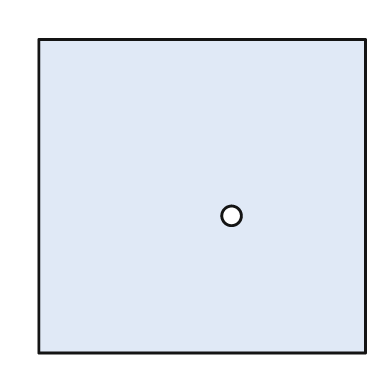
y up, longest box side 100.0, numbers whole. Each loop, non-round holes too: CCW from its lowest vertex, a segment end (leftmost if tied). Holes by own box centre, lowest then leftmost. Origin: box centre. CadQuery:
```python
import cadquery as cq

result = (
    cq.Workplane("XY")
    .moveTo(-50.0, -48.0)
    .lineTo(50.0, -48.0)
    .lineTo(50.0, 48.0)
    .lineTo(-50.0, 48.0)
    .close()
    .moveTo(9.0, -6.0)
    .circle(3.0)
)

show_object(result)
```